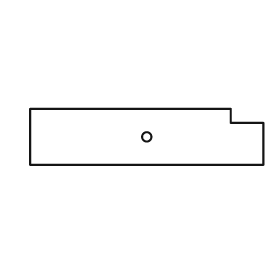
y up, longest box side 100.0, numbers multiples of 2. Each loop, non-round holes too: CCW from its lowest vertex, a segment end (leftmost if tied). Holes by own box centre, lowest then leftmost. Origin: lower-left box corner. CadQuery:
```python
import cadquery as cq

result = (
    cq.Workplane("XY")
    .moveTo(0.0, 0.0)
    .lineTo(100.0, 0.0)
    .lineTo(100.0, 18.0)
    .lineTo(86.0, 18.0)
    .lineTo(86.0, 24.0)
    .lineTo(0.0, 24.0)
    .close()
    .moveTo(50.0, 12.0)
    .circle(2.0)
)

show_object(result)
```